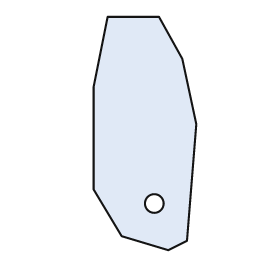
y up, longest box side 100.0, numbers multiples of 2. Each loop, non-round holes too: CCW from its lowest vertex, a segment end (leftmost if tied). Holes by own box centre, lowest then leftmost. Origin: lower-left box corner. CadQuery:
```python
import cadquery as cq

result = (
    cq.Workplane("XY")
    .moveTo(32.0, 0.0)
    .lineTo(40.0, 4.0)
    .lineTo(44.0, 54.0)
    .lineTo(38.0, 82.0)
    .lineTo(28.0, 100.0)
    .lineTo(6.0, 100.0)
    .lineTo(0.0, 70.0)
    .lineTo(0.0, 26.0)
    .lineTo(12.0, 6.0)
    .close()
    .moveTo(26.0, 20.0)
    .circle(4.0)
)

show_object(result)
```